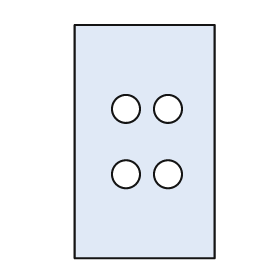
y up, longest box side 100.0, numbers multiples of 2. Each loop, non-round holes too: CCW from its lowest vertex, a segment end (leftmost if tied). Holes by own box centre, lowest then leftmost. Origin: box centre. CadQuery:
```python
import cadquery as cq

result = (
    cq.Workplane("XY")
    .moveTo(-30.0, -50.0)
    .lineTo(30.0, -50.0)
    .lineTo(30.0, 50.0)
    .lineTo(-30.0, 50.0)
    .close()
    .moveTo(-8.0, -14.0)
    .circle(6.0)
    .moveTo(10.0, -14.0)
    .circle(6.0)
    .moveTo(-8.0, 14.0)
    .circle(6.0)
    .moveTo(10.0, 14.0)
    .circle(6.0)
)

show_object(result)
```